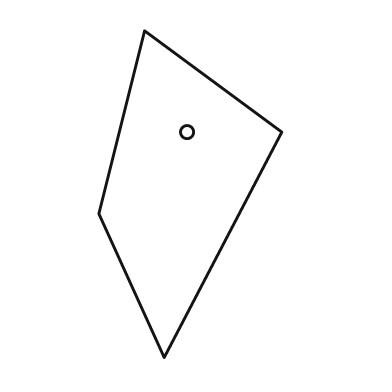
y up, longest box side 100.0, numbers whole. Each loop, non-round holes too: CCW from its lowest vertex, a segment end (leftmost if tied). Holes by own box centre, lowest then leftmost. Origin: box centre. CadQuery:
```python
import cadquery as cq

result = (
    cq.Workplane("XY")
    .moveTo(-8.0, -50.0)
    .lineTo(28.0, 19.0)
    .lineTo(-14.0, 50.0)
    .lineTo(-28.0, -6.0)
    .close()
    .moveTo(-1.0, 19.0)
    .circle(2.0)
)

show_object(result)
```